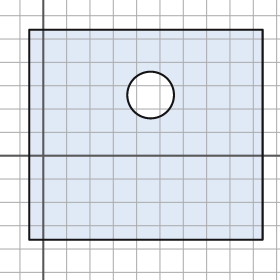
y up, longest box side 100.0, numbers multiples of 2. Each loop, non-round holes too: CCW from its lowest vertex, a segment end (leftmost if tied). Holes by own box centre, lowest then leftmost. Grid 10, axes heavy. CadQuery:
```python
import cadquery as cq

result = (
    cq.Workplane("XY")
    .moveTo(-6.0, -36.0)
    .lineTo(94.0, -36.0)
    .lineTo(94.0, 54.0)
    .lineTo(-6.0, 54.0)
    .close()
    .moveTo(46.0, 26.0)
    .circle(10.0)
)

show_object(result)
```